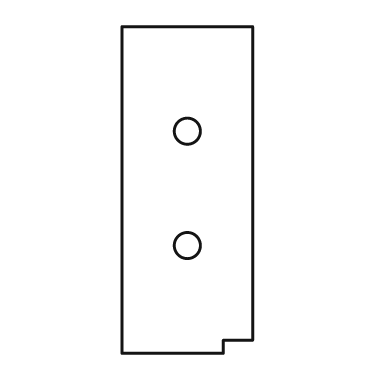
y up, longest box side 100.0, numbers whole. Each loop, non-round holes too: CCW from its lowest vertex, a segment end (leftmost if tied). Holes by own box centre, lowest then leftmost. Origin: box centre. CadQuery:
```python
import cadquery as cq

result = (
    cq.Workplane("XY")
    .moveTo(-20.0, -50.0)
    .lineTo(11.0, -50.0)
    .lineTo(11.0, -46.0)
    .lineTo(20.0, -46.0)
    .lineTo(20.0, 50.0)
    .lineTo(-20.0, 50.0)
    .close()
    .moveTo(0.0, -17.0)
    .circle(4.0)
    .moveTo(0.0, 18.0)
    .circle(4.0)
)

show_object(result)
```